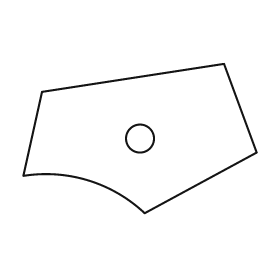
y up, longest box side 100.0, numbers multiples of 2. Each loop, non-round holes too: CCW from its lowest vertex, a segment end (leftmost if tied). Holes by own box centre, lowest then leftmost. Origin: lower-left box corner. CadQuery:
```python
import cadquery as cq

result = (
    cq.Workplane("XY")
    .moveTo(52.0, 0.0)
    .lineTo(100.0, 26.0)
    .lineTo(86.0, 64.0)
    .lineTo(8.0, 52.0)
    .lineTo(0.0, 16.0)
    .threePointArc((28.0, 14.0), (52.0, 0.0))
    .close()
    .moveTo(50.0, 32.0)
    .circle(6.0)
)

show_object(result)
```